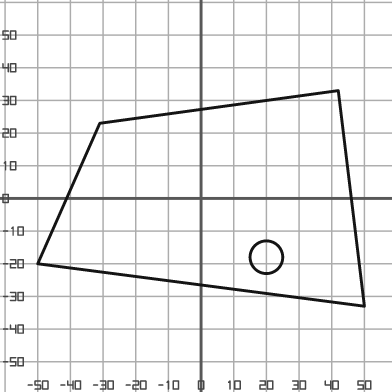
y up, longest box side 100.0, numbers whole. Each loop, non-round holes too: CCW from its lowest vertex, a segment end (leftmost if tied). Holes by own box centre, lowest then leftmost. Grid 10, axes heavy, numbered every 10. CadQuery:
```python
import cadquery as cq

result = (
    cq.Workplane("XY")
    .moveTo(50.0, -33.0)
    .lineTo(42.0, 33.0)
    .lineTo(-31.0, 23.0)
    .lineTo(-50.0, -20.0)
    .close()
    .moveTo(20.0, -18.0)
    .circle(5.0)
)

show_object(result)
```